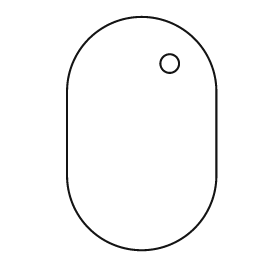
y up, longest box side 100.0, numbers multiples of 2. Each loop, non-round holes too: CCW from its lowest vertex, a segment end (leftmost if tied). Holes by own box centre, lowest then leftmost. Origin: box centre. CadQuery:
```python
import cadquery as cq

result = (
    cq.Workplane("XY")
    .moveTo(-32.0, -18.0)
    .threePointArc((0.0, -50.0), (32.0, -18.0))
    .lineTo(32.0, 18.0)
    .threePointArc((0.0, 50.0), (-32.0, 18.0))
    .close()
    .moveTo(12.0, 30.0)
    .circle(4.0)
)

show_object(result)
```